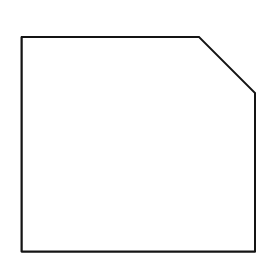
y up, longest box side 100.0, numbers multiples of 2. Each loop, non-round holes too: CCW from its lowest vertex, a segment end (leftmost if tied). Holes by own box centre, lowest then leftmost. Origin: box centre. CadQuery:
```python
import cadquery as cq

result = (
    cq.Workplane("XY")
    .moveTo(-50.0, -46.0)
    .lineTo(50.0, -46.0)
    .lineTo(50.0, 22.0)
    .lineTo(26.0, 46.0)
    .lineTo(-50.0, 46.0)
    .close()
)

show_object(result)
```